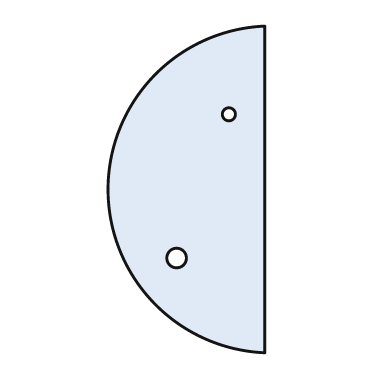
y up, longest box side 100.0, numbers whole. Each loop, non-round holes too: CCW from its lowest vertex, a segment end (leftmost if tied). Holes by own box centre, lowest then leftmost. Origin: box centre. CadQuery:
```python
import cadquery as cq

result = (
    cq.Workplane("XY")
    .moveTo(24.0, -50.0)
    .lineTo(24.0, 50.0)
    .threePointArc((-24.0, 0.0), (24.0, -50.0))
    .close()
    .moveTo(-3.0, -21.0)
    .circle(3.0)
    .moveTo(13.0, 23.0)
    .circle(2.0)
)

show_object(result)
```